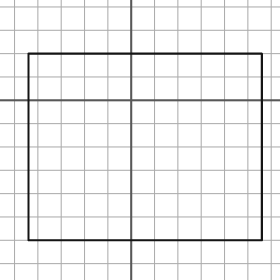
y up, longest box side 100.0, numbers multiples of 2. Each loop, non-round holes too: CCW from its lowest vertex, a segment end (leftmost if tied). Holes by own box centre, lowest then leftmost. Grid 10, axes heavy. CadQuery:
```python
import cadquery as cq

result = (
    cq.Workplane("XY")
    .moveTo(-44.0, -60.0)
    .lineTo(56.0, -60.0)
    .lineTo(56.0, 20.0)
    .lineTo(-44.0, 20.0)
    .close()
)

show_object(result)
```